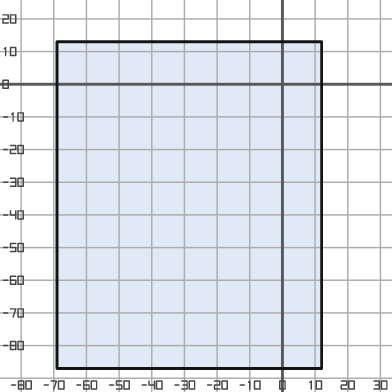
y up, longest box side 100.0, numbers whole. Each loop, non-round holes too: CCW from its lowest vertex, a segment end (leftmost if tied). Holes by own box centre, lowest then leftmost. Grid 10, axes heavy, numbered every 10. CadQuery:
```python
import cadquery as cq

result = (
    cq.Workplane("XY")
    .moveTo(-69.0, -87.0)
    .lineTo(12.0, -87.0)
    .lineTo(12.0, 13.0)
    .lineTo(-69.0, 13.0)
    .close()
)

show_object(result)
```